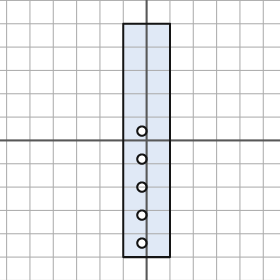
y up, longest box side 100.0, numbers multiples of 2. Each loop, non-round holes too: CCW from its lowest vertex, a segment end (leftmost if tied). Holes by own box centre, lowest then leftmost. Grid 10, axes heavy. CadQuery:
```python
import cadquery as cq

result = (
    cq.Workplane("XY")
    .moveTo(-10.0, -50.0)
    .lineTo(10.0, -50.0)
    .lineTo(10.0, 50.0)
    .lineTo(-10.0, 50.0)
    .close()
    .moveTo(-2.0, -44.0)
    .circle(2.0)
    .moveTo(-2.0, -32.0)
    .circle(2.0)
    .moveTo(-2.0, -20.0)
    .circle(2.0)
    .moveTo(-2.0, -8.0)
    .circle(2.0)
    .moveTo(-2.0, 4.0)
    .circle(2.0)
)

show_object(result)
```